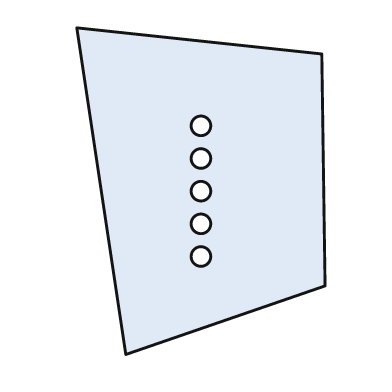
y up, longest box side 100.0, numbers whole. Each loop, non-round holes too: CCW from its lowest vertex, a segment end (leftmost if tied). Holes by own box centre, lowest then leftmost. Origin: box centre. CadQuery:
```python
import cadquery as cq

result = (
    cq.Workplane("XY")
    .moveTo(-23.0, -50.0)
    .lineTo(38.0, -29.0)
    .lineTo(37.0, 42.0)
    .lineTo(-38.0, 50.0)
    .close()
    .moveTo(0.0, -20.0)
    .circle(3.0)
    .moveTo(0.0, -10.0)
    .circle(3.0)
    .moveTo(0.0, 0.0)
    .circle(3.0)
    .moveTo(0.0, 10.0)
    .circle(3.0)
    .moveTo(0.0, 20.0)
    .circle(3.0)
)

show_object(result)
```